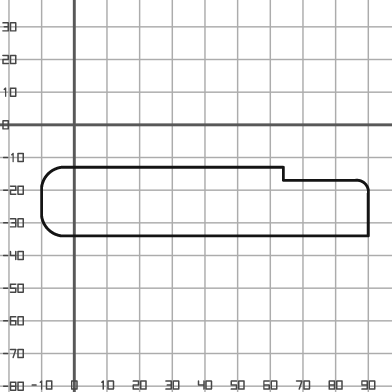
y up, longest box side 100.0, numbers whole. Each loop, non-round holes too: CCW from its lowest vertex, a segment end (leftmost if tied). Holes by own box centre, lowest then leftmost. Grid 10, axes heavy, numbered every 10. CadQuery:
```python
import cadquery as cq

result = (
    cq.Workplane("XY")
    .moveTo(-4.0, -34.0)
    .lineTo(90.0, -34.0)
    .lineTo(90.0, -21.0)
    .threePointArc((89.0, -18.0), (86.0, -17.0))
    .lineTo(64.0, -17.0)
    .lineTo(64.0, -13.0)
    .lineTo(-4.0, -13.0)
    .threePointArc((-8.0, -15.0), (-10.0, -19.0))
    .lineTo(-10.0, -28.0)
    .threePointArc((-8.0, -32.0), (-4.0, -34.0))
    .close()
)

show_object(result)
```